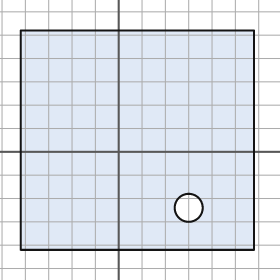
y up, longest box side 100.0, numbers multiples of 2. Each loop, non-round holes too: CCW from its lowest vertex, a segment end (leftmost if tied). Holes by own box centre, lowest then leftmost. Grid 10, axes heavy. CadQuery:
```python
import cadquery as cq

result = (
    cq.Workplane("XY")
    .moveTo(-42.0, -42.0)
    .lineTo(58.0, -42.0)
    .lineTo(58.0, 52.0)
    .lineTo(-42.0, 52.0)
    .close()
    .moveTo(30.0, -24.0)
    .circle(6.0)
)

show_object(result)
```